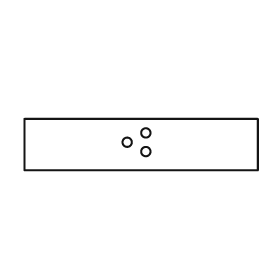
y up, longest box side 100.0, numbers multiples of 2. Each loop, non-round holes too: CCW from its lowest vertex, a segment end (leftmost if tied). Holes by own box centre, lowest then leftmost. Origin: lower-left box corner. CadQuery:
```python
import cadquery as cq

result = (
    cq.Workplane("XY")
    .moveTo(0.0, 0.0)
    .lineTo(100.0, 0.0)
    .lineTo(100.0, 22.0)
    .lineTo(0.0, 22.0)
    .close()
    .moveTo(52.0, 8.0)
    .circle(2.0)
    .moveTo(44.0, 12.0)
    .circle(2.0)
    .moveTo(52.0, 16.0)
    .circle(2.0)
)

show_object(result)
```